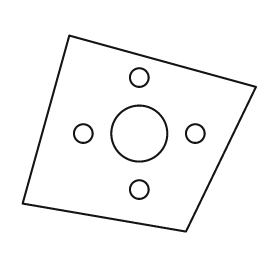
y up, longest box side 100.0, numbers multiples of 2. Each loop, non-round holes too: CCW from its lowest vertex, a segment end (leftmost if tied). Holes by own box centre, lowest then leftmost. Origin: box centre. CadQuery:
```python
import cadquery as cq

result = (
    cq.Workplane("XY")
    .moveTo(20.0, -42.0)
    .lineTo(50.0, 20.0)
    .lineTo(-30.0, 42.0)
    .lineTo(-50.0, -30.0)
    .close()
    .moveTo(0.0, -24.0)
    .circle(4.0)
    .moveTo(-24.0, 0.0)
    .circle(4.0)
    .moveTo(0.0, 0.0)
    .circle(12.0)
    .moveTo(24.0, 0.0)
    .circle(4.0)
    .moveTo(0.0, 24.0)
    .circle(4.0)
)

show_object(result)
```